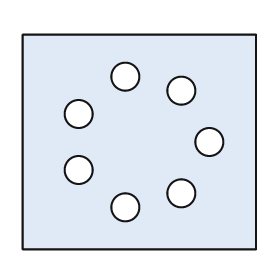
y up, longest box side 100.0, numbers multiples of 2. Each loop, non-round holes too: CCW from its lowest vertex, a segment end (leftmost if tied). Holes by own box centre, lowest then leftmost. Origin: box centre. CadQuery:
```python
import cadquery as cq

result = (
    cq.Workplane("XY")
    .moveTo(-50.0, -46.0)
    .lineTo(50.0, -46.0)
    .lineTo(50.0, 46.0)
    .lineTo(-50.0, 46.0)
    .close()
    .moveTo(-6.0, -28.0)
    .circle(6.0)
    .moveTo(18.0, -22.0)
    .circle(6.0)
    .moveTo(-26.0, -12.0)
    .circle(6.0)
    .moveTo(30.0, 0.0)
    .circle(6.0)
    .moveTo(-26.0, 12.0)
    .circle(6.0)
    .moveTo(18.0, 22.0)
    .circle(6.0)
    .moveTo(-6.0, 28.0)
    .circle(6.0)
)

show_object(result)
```